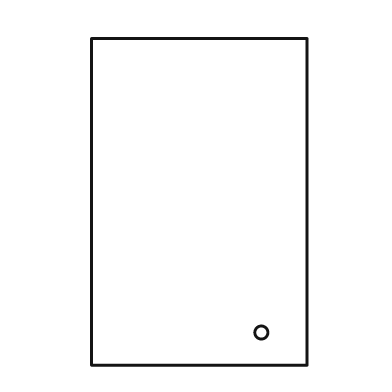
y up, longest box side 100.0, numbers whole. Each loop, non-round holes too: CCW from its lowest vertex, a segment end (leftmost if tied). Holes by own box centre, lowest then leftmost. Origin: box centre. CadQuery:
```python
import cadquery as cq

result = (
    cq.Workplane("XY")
    .moveTo(-33.0, -50.0)
    .lineTo(33.0, -50.0)
    .lineTo(33.0, 50.0)
    .lineTo(-33.0, 50.0)
    .close()
    .moveTo(19.0, -40.0)
    .circle(2.0)
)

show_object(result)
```